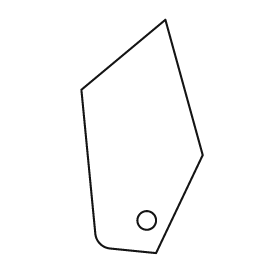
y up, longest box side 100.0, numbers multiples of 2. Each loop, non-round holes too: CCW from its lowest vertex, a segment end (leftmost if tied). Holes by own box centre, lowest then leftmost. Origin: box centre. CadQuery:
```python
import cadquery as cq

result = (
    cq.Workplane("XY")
    .moveTo(6.0, -50.0)
    .lineTo(26.0, -8.0)
    .lineTo(10.0, 50.0)
    .lineTo(-26.0, 20.0)
    .lineTo(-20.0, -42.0)
    .threePointArc((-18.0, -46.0), (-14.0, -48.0))
    .close()
    .moveTo(2.0, -36.0)
    .circle(4.0)
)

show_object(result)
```